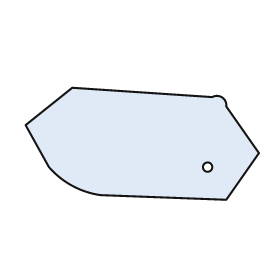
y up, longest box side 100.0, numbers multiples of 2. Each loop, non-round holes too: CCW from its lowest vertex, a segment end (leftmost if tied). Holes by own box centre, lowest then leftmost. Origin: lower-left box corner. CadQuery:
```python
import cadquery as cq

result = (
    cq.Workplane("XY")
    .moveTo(86.0, 0.0)
    .lineTo(100.0, 20.0)
    .lineTo(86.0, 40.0)
    .threePointArc((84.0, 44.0), (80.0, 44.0))
    .lineTo(20.0, 48.0)
    .lineTo(0.0, 32.0)
    .lineTo(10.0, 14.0)
    .threePointArc((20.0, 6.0), (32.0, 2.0))
    .close()
    .moveTo(78.0, 14.0)
    .circle(2.0)
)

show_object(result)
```